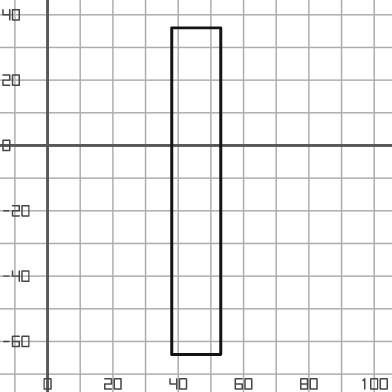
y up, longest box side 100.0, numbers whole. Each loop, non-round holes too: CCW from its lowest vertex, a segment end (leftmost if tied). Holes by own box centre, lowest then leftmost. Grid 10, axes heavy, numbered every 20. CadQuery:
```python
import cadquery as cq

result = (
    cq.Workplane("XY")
    .moveTo(38.0, -64.0)
    .lineTo(53.0, -64.0)
    .lineTo(53.0, 36.0)
    .lineTo(38.0, 36.0)
    .close()
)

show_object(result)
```